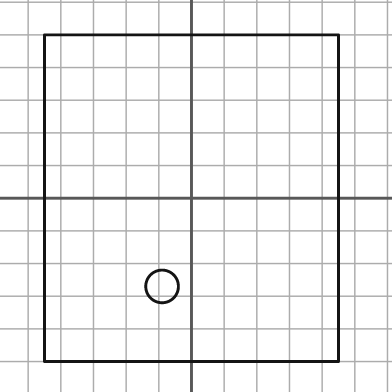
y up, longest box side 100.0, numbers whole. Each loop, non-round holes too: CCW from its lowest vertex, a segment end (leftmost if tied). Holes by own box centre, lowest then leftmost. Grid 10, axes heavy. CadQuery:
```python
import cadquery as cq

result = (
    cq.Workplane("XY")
    .moveTo(-45.0, -50.0)
    .lineTo(45.0, -50.0)
    .lineTo(45.0, 50.0)
    .lineTo(-45.0, 50.0)
    .close()
    .moveTo(-9.0, -27.0)
    .circle(5.0)
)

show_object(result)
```